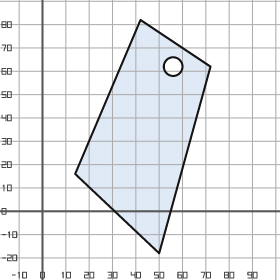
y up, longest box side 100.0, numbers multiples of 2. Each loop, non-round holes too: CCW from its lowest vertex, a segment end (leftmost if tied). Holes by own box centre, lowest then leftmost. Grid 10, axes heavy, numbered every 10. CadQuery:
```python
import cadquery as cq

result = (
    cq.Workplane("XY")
    .moveTo(50.0, -18.0)
    .lineTo(72.0, 62.0)
    .lineTo(42.0, 82.0)
    .lineTo(14.0, 16.0)
    .close()
    .moveTo(56.0, 62.0)
    .circle(4.0)
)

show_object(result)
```